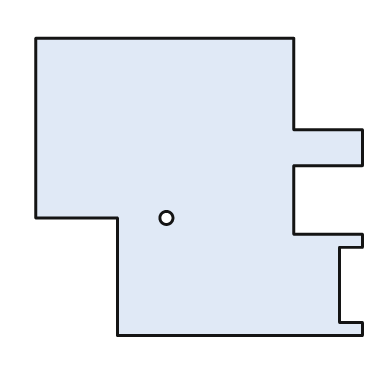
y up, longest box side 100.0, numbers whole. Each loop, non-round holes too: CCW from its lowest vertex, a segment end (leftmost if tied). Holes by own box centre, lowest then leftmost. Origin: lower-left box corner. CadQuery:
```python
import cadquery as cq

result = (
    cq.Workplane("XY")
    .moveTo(25.0, 0.0)
    .lineTo(100.0, 0.0)
    .lineTo(100.0, 4.0)
    .lineTo(93.0, 4.0)
    .lineTo(93.0, 27.0)
    .lineTo(100.0, 27.0)
    .lineTo(100.0, 31.0)
    .lineTo(79.0, 31.0)
    .lineTo(79.0, 52.0)
    .lineTo(100.0, 52.0)
    .lineTo(100.0, 63.0)
    .lineTo(79.0, 63.0)
    .lineTo(79.0, 91.0)
    .lineTo(0.0, 91.0)
    .lineTo(0.0, 36.0)
    .lineTo(25.0, 36.0)
    .close()
    .moveTo(40.0, 36.0)
    .circle(2.0)
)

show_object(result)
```